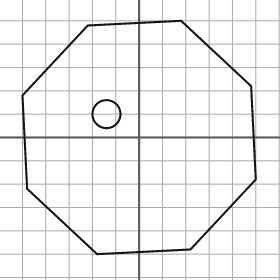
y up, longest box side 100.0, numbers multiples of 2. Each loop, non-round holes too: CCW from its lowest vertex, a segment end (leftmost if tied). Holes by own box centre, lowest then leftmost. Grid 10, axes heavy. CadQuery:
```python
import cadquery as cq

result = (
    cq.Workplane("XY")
    .moveTo(-18.0, -50.0)
    .lineTo(22.0, -48.0)
    .lineTo(50.0, -18.0)
    .lineTo(48.0, 22.0)
    .lineTo(18.0, 50.0)
    .lineTo(-22.0, 48.0)
    .lineTo(-50.0, 18.0)
    .lineTo(-48.0, -22.0)
    .close()
    .moveTo(-14.0, 10.0)
    .circle(6.0)
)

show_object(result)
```